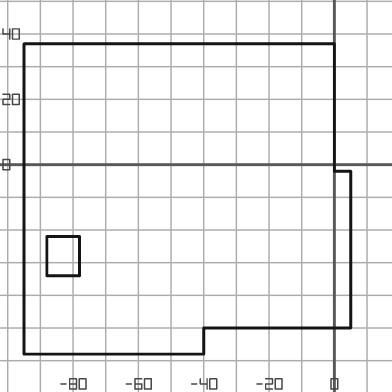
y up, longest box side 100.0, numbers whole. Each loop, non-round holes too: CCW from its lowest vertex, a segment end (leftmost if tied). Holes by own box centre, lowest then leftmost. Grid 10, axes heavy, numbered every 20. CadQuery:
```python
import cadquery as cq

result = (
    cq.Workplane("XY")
    .moveTo(-95.0, -58.0)
    .lineTo(-40.0, -58.0)
    .lineTo(-40.0, -50.0)
    .lineTo(5.0, -50.0)
    .lineTo(5.0, -2.0)
    .lineTo(0.0, -2.0)
    .lineTo(0.0, 37.0)
    .lineTo(-95.0, 37.0)
    .close()
    .moveTo(-88.0, -34.0)
    .lineTo(-78.0, -34.0)
    .lineTo(-78.0, -22.0)
    .lineTo(-88.0, -22.0)
    .close()
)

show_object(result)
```